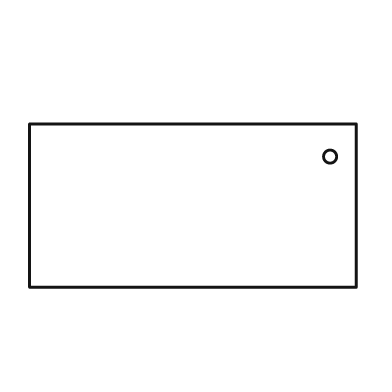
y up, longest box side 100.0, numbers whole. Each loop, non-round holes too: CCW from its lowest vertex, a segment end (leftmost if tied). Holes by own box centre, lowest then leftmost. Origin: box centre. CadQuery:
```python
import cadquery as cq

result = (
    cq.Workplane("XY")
    .moveTo(-50.0, -25.0)
    .lineTo(50.0, -25.0)
    .lineTo(50.0, 25.0)
    .lineTo(-50.0, 25.0)
    .close()
    .moveTo(42.0, 15.0)
    .circle(2.0)
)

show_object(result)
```